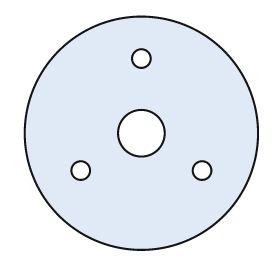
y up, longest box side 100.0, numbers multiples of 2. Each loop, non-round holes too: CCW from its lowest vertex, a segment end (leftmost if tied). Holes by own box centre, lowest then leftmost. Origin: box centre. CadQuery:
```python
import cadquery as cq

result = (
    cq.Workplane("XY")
    .moveTo(0.0, 0.0)
    .circle(50.0)
    .moveTo(-26.0, -16.0)
    .circle(4.0)
    .moveTo(26.0, -16.0)
    .circle(4.0)
    .moveTo(0.0, 0.0)
    .circle(10.0)
    .moveTo(0.0, 32.0)
    .circle(4.0)
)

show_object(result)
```